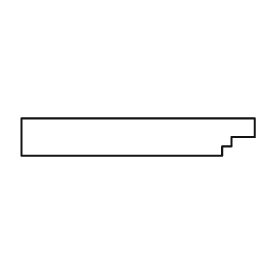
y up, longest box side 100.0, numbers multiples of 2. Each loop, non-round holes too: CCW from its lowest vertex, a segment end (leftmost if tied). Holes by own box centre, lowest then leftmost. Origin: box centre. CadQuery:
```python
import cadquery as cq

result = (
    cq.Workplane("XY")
    .moveTo(-50.0, -8.0)
    .lineTo(36.0, -8.0)
    .lineTo(36.0, -4.0)
    .lineTo(40.0, -4.0)
    .lineTo(40.0, 0.0)
    .lineTo(50.0, 0.0)
    .lineTo(50.0, 8.0)
    .lineTo(-50.0, 8.0)
    .close()
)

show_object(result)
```